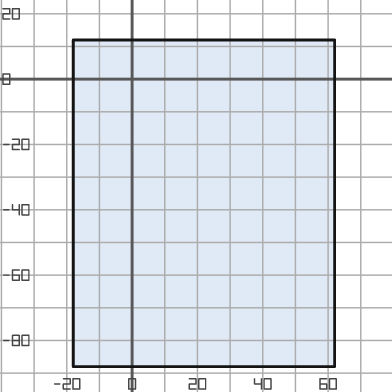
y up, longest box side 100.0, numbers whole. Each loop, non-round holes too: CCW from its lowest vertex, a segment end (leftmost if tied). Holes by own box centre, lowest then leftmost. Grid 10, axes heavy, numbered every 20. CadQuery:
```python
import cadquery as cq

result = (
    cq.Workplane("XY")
    .moveTo(-18.0, -88.0)
    .lineTo(62.0, -88.0)
    .lineTo(62.0, 12.0)
    .lineTo(-18.0, 12.0)
    .close()
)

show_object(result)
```